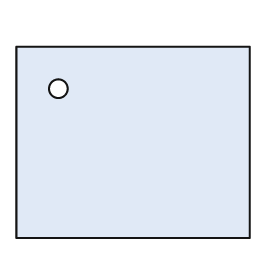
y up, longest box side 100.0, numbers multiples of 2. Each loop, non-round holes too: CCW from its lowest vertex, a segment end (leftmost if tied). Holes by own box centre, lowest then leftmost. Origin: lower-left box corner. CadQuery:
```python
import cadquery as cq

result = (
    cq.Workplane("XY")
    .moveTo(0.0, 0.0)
    .lineTo(100.0, 0.0)
    .lineTo(100.0, 82.0)
    .lineTo(0.0, 82.0)
    .close()
    .moveTo(18.0, 64.0)
    .circle(4.0)
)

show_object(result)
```